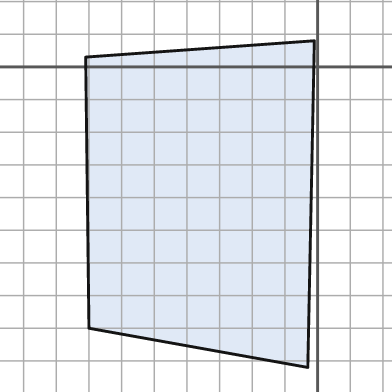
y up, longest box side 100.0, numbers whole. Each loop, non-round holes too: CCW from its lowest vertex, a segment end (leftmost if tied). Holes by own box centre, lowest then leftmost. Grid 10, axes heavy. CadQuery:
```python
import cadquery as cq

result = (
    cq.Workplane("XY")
    .moveTo(-3.0, -92.0)
    .lineTo(-1.0, 8.0)
    .lineTo(-71.0, 3.0)
    .lineTo(-70.0, -80.0)
    .close()
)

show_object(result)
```